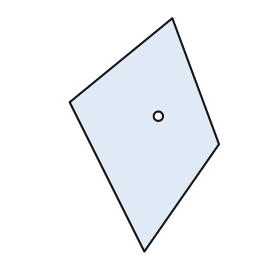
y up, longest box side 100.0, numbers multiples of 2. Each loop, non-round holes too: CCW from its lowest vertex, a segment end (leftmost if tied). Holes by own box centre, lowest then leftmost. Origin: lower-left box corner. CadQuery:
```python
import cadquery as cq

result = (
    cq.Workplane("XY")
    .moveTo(32.0, 0.0)
    .lineTo(64.0, 46.0)
    .lineTo(44.0, 100.0)
    .lineTo(0.0, 64.0)
    .close()
    .moveTo(38.0, 58.0)
    .circle(2.0)
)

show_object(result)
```